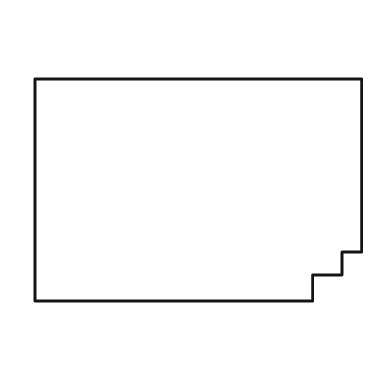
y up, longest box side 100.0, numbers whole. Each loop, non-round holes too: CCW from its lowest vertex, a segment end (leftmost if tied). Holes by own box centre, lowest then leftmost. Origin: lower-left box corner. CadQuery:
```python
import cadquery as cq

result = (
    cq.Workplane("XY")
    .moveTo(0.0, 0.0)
    .lineTo(85.0, 0.0)
    .lineTo(85.0, 8.0)
    .lineTo(94.0, 8.0)
    .lineTo(94.0, 15.0)
    .lineTo(100.0, 15.0)
    .lineTo(100.0, 68.0)
    .lineTo(0.0, 68.0)
    .close()
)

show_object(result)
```